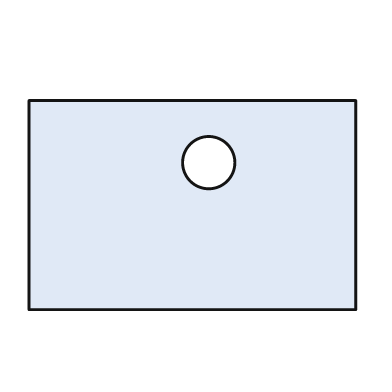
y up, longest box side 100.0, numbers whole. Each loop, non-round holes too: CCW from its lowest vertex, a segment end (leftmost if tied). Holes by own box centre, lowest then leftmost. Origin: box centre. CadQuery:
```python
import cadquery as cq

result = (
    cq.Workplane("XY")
    .moveTo(-50.0, -32.0)
    .lineTo(50.0, -32.0)
    .lineTo(50.0, 32.0)
    .lineTo(-50.0, 32.0)
    .close()
    .moveTo(5.0, 13.0)
    .circle(8.0)
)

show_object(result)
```